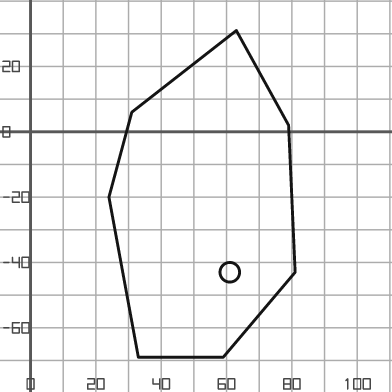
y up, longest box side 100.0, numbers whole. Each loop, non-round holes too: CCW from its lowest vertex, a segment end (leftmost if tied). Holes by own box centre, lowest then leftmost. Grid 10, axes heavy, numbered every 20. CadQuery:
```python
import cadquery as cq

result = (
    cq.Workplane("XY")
    .moveTo(33.0, -69.0)
    .lineTo(59.0, -69.0)
    .lineTo(81.0, -43.0)
    .lineTo(79.0, 2.0)
    .lineTo(63.0, 31.0)
    .lineTo(31.0, 6.0)
    .lineTo(24.0, -20.0)
    .close()
    .moveTo(61.0, -43.0)
    .circle(3.0)
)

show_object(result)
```